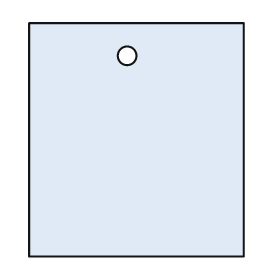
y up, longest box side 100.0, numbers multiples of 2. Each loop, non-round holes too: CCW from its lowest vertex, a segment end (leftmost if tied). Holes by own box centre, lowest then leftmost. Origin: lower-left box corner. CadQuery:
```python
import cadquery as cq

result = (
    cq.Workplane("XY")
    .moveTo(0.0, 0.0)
    .lineTo(92.0, 0.0)
    .lineTo(92.0, 100.0)
    .lineTo(0.0, 100.0)
    .close()
    .moveTo(42.0, 86.0)
    .circle(4.0)
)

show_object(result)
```